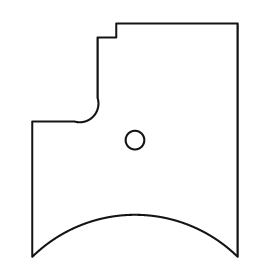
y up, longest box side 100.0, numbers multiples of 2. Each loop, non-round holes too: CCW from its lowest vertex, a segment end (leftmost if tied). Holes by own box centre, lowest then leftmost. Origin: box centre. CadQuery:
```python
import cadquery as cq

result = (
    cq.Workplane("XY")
    .moveTo(-44.0, -50.0)
    .threePointArc((0.0, -32.0), (44.0, -50.0))
    .lineTo(44.0, 50.0)
    .lineTo(-8.0, 50.0)
    .lineTo(-8.0, 44.0)
    .lineTo(-16.0, 44.0)
    .lineTo(-16.0, 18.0)
    .threePointArc((-18.0, 10.0), (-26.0, 8.0))
    .lineTo(-44.0, 8.0)
    .close()
    .moveTo(0.0, 0.0)
    .circle(4.0)
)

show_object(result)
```